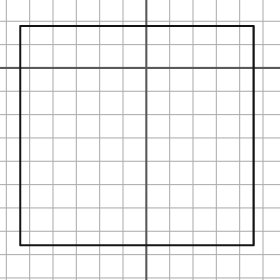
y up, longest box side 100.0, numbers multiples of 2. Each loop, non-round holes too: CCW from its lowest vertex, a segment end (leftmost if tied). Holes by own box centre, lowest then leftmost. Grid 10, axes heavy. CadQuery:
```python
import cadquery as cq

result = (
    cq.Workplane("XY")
    .moveTo(-54.0, -76.0)
    .lineTo(46.0, -76.0)
    .lineTo(46.0, 18.0)
    .lineTo(-54.0, 18.0)
    .close()
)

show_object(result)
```